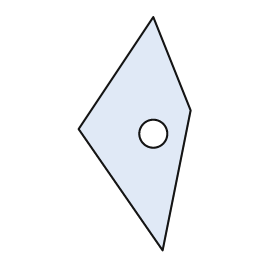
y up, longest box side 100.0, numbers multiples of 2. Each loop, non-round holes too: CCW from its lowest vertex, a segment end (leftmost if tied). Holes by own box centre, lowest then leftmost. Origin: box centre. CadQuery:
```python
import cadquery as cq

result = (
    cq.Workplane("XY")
    .moveTo(12.0, -50.0)
    .lineTo(24.0, 10.0)
    .lineTo(8.0, 50.0)
    .lineTo(-24.0, 2.0)
    .close()
    .moveTo(8.0, 0.0)
    .circle(6.0)
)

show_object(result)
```